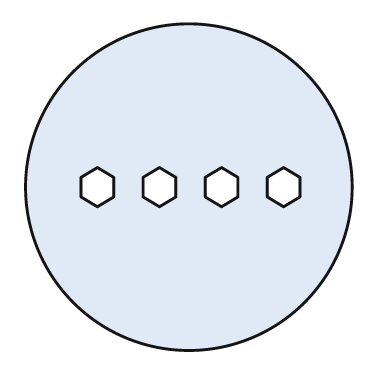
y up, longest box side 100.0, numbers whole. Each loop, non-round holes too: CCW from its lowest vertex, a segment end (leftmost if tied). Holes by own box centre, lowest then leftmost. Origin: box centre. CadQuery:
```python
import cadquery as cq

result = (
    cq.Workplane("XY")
    .moveTo(0.0, 0.0)
    .circle(50.0)
    .moveTo(-28.0, -6.0)
    .lineTo(-23.0, -3.0)
    .lineTo(-23.0, 3.0)
    .lineTo(-28.0, 6.0)
    .lineTo(-33.0, 3.0)
    .lineTo(-33.0, -3.0)
    .close()
    .moveTo(-9.0, -6.0)
    .lineTo(-4.0, -3.0)
    .lineTo(-4.0, 3.0)
    .lineTo(-9.0, 6.0)
    .lineTo(-14.0, 3.0)
    .lineTo(-14.0, -3.0)
    .close()
    .moveTo(10.0, -6.0)
    .lineTo(15.0, -3.0)
    .lineTo(15.0, 3.0)
    .lineTo(10.0, 6.0)
    .lineTo(5.0, 3.0)
    .lineTo(5.0, -3.0)
    .close()
    .moveTo(29.0, -6.0)
    .lineTo(34.0, -3.0)
    .lineTo(34.0, 3.0)
    .lineTo(29.0, 6.0)
    .lineTo(24.0, 3.0)
    .lineTo(24.0, -3.0)
    .close()
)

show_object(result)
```